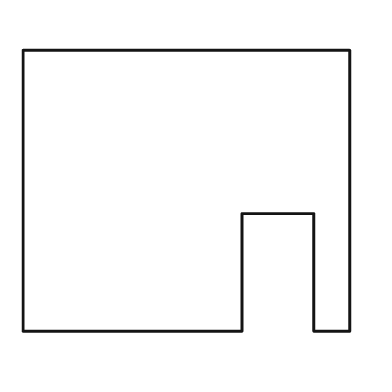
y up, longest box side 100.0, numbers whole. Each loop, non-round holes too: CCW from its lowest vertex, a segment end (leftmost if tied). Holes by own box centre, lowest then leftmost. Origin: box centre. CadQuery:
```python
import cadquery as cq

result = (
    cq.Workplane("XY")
    .moveTo(-50.0, -43.0)
    .lineTo(17.0, -43.0)
    .lineTo(17.0, -7.0)
    .lineTo(39.0, -7.0)
    .lineTo(39.0, -43.0)
    .lineTo(50.0, -43.0)
    .lineTo(50.0, 43.0)
    .lineTo(-50.0, 43.0)
    .close()
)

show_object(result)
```